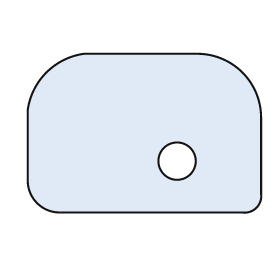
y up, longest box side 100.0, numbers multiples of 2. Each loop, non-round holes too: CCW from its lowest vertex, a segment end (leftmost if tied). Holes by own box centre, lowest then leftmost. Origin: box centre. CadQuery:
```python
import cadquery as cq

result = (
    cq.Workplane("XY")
    .moveTo(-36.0, -34.0)
    .lineTo(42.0, -34.0)
    .threePointArc((48.0, -32.0), (50.0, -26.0))
    .lineTo(50.0, 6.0)
    .threePointArc((42.0, 26.0), (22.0, 34.0))
    .lineTo(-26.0, 34.0)
    .threePointArc((-42.0, 26.0), (-50.0, 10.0))
    .lineTo(-50.0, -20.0)
    .threePointArc((-46.0, -30.0), (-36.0, -34.0))
    .close()
    .moveTo(14.0, -12.0)
    .circle(8.0)
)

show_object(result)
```